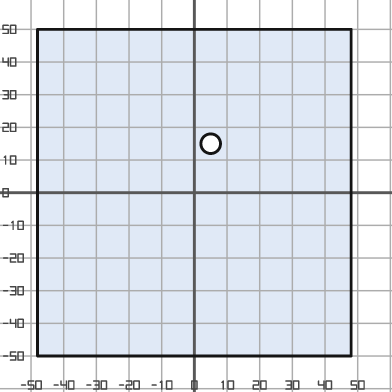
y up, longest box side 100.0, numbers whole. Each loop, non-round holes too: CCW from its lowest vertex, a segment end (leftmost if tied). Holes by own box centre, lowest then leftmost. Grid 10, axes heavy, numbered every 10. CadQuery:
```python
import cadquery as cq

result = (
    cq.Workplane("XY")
    .moveTo(-48.0, -50.0)
    .lineTo(48.0, -50.0)
    .lineTo(48.0, 50.0)
    .lineTo(-48.0, 50.0)
    .close()
    .moveTo(5.0, 15.0)
    .circle(3.0)
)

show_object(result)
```